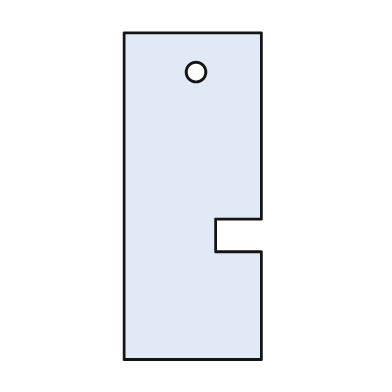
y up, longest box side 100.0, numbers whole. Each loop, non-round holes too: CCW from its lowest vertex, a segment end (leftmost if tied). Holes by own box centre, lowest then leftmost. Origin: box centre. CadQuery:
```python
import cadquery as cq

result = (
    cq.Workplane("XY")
    .moveTo(-21.0, -50.0)
    .lineTo(21.0, -50.0)
    .lineTo(21.0, -17.0)
    .lineTo(7.0, -17.0)
    .lineTo(7.0, -7.0)
    .lineTo(21.0, -7.0)
    .lineTo(21.0, 50.0)
    .lineTo(-21.0, 50.0)
    .close()
    .moveTo(1.0, 38.0)
    .circle(3.0)
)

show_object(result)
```